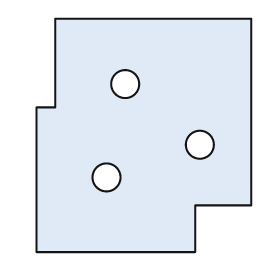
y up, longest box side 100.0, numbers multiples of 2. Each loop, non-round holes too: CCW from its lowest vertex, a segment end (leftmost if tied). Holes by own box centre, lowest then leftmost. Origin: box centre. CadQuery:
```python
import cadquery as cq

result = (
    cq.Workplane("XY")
    .moveTo(-46.0, -50.0)
    .lineTo(22.0, -50.0)
    .lineTo(22.0, -30.0)
    .lineTo(46.0, -30.0)
    .lineTo(46.0, 50.0)
    .lineTo(-38.0, 50.0)
    .lineTo(-38.0, 12.0)
    .lineTo(-46.0, 12.0)
    .close()
    .moveTo(-16.0, -18.0)
    .circle(6.0)
    .moveTo(24.0, -4.0)
    .circle(6.0)
    .moveTo(-8.0, 22.0)
    .circle(6.0)
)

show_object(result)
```